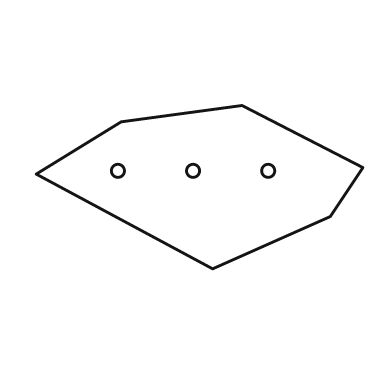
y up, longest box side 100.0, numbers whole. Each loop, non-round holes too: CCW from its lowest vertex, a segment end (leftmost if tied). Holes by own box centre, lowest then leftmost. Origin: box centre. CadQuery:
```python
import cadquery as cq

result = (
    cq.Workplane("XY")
    .moveTo(4.0, -25.0)
    .lineTo(40.0, -9.0)
    .lineTo(50.0, 6.0)
    .lineTo(13.0, 25.0)
    .lineTo(-24.0, 20.0)
    .lineTo(-50.0, 4.0)
    .close()
    .moveTo(-25.0, 5.0)
    .circle(2.0)
    .moveTo(-2.0, 5.0)
    .circle(2.0)
    .moveTo(21.0, 5.0)
    .circle(2.0)
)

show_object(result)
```